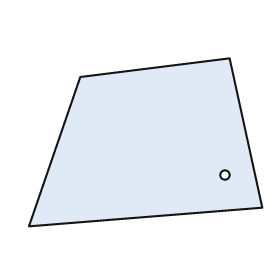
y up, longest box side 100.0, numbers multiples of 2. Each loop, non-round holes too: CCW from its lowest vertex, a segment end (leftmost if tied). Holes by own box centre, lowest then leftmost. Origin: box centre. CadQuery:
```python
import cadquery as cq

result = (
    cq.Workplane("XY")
    .moveTo(-50.0, -36.0)
    .lineTo(50.0, -28.0)
    .lineTo(36.0, 36.0)
    .lineTo(-28.0, 28.0)
    .close()
    .moveTo(34.0, -14.0)
    .circle(2.0)
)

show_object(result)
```